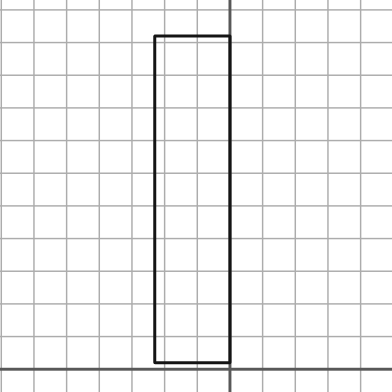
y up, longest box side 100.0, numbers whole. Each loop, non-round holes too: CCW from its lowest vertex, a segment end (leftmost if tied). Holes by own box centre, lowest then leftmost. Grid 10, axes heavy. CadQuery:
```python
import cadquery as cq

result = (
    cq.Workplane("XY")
    .moveTo(-23.0, 2.0)
    .lineTo(0.0, 2.0)
    .lineTo(0.0, 102.0)
    .lineTo(-23.0, 102.0)
    .close()
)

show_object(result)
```